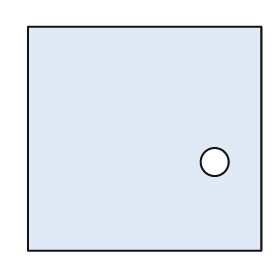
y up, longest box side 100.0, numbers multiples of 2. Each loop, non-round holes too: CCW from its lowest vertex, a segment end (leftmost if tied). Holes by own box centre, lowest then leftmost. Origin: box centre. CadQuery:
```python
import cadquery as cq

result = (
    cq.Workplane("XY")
    .moveTo(-50.0, -48.0)
    .lineTo(50.0, -48.0)
    .lineTo(50.0, 48.0)
    .lineTo(-50.0, 48.0)
    .close()
    .moveTo(30.0, -10.0)
    .circle(6.0)
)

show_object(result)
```